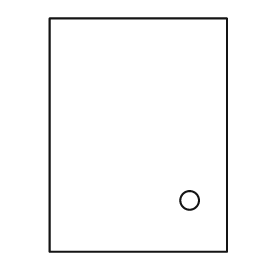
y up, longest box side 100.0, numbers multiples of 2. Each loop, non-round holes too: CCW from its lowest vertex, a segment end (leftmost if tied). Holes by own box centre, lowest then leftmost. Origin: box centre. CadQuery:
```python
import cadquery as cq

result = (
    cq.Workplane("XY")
    .moveTo(-38.0, -50.0)
    .lineTo(38.0, -50.0)
    .lineTo(38.0, 50.0)
    .lineTo(-38.0, 50.0)
    .close()
    .moveTo(22.0, -28.0)
    .circle(4.0)
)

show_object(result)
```